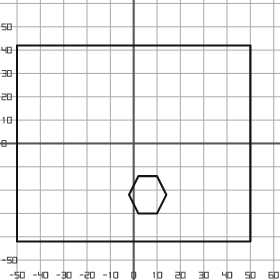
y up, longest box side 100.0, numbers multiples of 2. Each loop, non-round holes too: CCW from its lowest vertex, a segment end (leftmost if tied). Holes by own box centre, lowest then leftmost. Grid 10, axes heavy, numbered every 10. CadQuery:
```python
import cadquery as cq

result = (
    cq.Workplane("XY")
    .moveTo(-50.0, -42.0)
    .lineTo(50.0, -42.0)
    .lineTo(50.0, 42.0)
    .lineTo(-50.0, 42.0)
    .close()
    .moveTo(2.0, -30.0)
    .lineTo(10.0, -30.0)
    .lineTo(14.0, -22.0)
    .lineTo(10.0, -14.0)
    .lineTo(2.0, -14.0)
    .lineTo(-2.0, -22.0)
    .close()
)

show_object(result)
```